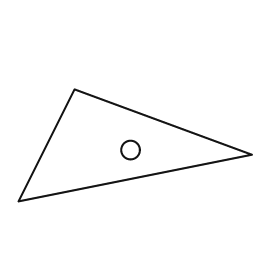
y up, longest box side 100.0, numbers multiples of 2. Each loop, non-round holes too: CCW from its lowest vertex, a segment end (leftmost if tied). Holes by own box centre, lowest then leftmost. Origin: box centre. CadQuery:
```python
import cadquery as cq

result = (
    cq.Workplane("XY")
    .moveTo(-50.0, -24.0)
    .lineTo(50.0, -4.0)
    .lineTo(-26.0, 24.0)
    .close()
    .moveTo(-2.0, -2.0)
    .circle(4.0)
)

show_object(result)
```